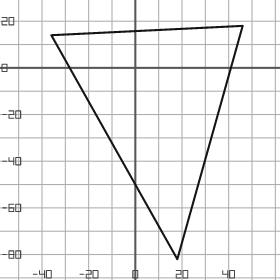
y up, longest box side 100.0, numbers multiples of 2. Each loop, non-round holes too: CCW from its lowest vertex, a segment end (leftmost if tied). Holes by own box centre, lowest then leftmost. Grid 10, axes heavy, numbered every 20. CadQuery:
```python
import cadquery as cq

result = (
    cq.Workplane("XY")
    .moveTo(18.0, -82.0)
    .lineTo(46.0, 18.0)
    .lineTo(-36.0, 14.0)
    .close()
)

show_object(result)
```